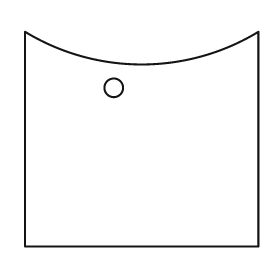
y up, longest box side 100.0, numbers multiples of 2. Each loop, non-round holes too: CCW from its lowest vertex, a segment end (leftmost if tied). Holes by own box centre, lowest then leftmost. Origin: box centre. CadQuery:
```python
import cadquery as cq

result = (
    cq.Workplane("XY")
    .moveTo(-50.0, -46.0)
    .lineTo(50.0, -46.0)
    .lineTo(50.0, 46.0)
    .threePointArc((0.0, 32.0), (-50.0, 46.0))
    .close()
    .moveTo(-12.0, 22.0)
    .circle(4.0)
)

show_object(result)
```